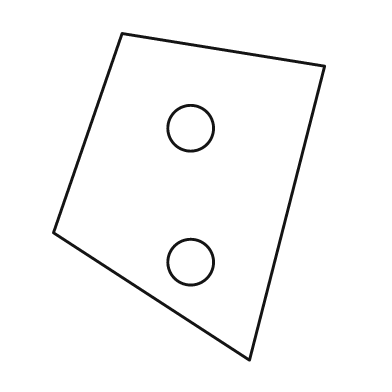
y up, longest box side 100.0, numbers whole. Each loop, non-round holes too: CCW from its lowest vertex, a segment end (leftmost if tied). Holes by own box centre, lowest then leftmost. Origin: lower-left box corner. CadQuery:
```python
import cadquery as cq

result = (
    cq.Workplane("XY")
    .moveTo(60.0, 0.0)
    .lineTo(83.0, 90.0)
    .lineTo(21.0, 100.0)
    .lineTo(0.0, 39.0)
    .close()
    .moveTo(42.0, 30.0)
    .circle(7.0)
    .moveTo(42.0, 71.0)
    .circle(7.0)
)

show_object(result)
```